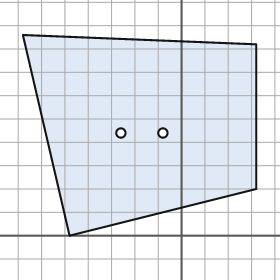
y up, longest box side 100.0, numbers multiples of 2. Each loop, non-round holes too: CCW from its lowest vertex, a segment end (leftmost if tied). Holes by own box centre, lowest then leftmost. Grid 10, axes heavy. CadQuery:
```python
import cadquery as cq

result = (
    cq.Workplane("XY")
    .moveTo(-48.0, 0.0)
    .lineTo(32.0, 20.0)
    .lineTo(32.0, 82.0)
    .lineTo(-68.0, 86.0)
    .close()
    .moveTo(-26.0, 44.0)
    .circle(2.0)
    .moveTo(-8.0, 44.0)
    .circle(2.0)
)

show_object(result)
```